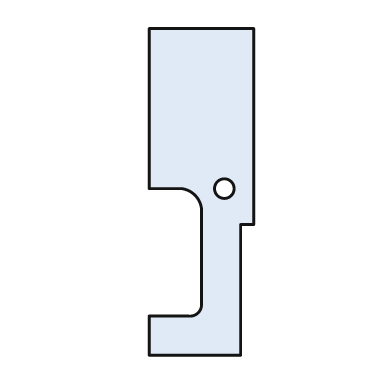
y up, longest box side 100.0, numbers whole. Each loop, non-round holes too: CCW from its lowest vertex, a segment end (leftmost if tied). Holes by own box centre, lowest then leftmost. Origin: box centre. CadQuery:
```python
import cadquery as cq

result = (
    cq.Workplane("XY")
    .moveTo(-16.0, -50.0)
    .lineTo(12.0, -50.0)
    .lineTo(12.0, -10.0)
    .lineTo(16.0, -10.0)
    .lineTo(16.0, 50.0)
    .lineTo(-16.0, 50.0)
    .lineTo(-16.0, 1.0)
    .lineTo(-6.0, 1.0)
    .threePointArc((-2.0, -1.0), (0.0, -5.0))
    .lineTo(0.0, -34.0)
    .threePointArc((-1.0, -37.0), (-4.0, -38.0))
    .lineTo(-16.0, -38.0)
    .close()
    .moveTo(7.0, 1.0)
    .circle(3.0)
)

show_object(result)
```